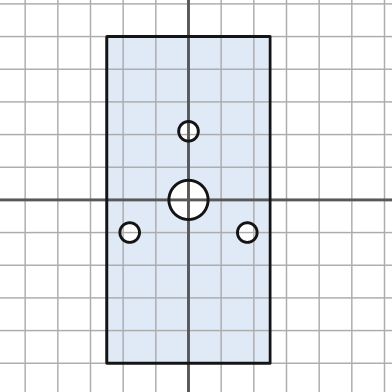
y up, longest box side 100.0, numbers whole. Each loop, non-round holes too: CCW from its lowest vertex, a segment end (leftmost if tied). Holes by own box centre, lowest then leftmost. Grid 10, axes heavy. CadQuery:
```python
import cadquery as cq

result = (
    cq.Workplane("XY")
    .moveTo(-25.0, -50.0)
    .lineTo(25.0, -50.0)
    .lineTo(25.0, 50.0)
    .lineTo(-25.0, 50.0)
    .close()
    .moveTo(-18.0, -10.0)
    .circle(3.0)
    .moveTo(18.0, -10.0)
    .circle(3.0)
    .moveTo(0.0, 0.0)
    .circle(6.0)
    .moveTo(0.0, 21.0)
    .circle(3.0)
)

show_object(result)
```